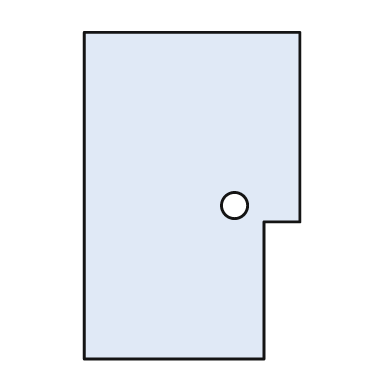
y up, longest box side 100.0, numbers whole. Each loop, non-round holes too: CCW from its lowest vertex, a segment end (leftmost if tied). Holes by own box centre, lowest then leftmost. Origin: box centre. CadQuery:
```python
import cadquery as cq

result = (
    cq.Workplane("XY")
    .moveTo(-33.0, -50.0)
    .lineTo(22.0, -50.0)
    .lineTo(22.0, -8.0)
    .lineTo(33.0, -8.0)
    .lineTo(33.0, 50.0)
    .lineTo(-33.0, 50.0)
    .close()
    .moveTo(13.0, -3.0)
    .circle(4.0)
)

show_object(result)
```